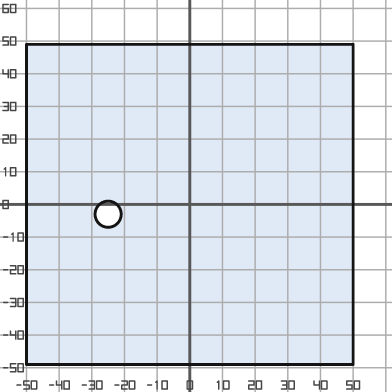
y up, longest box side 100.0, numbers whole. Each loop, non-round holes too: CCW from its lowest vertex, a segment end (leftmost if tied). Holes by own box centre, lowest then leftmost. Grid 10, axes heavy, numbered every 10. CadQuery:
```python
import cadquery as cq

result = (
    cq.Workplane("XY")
    .moveTo(-50.0, -49.0)
    .lineTo(50.0, -49.0)
    .lineTo(50.0, 49.0)
    .lineTo(-50.0, 49.0)
    .close()
    .moveTo(-25.0, -3.0)
    .circle(4.0)
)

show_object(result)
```